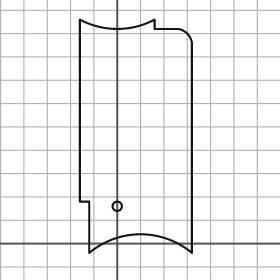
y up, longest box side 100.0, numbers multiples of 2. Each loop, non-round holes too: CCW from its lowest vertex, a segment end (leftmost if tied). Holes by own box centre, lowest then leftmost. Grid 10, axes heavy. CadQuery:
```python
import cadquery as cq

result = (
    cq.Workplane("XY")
    .moveTo(-12.0, -4.0)
    .threePointArc((10.0, 4.0), (32.0, -4.0))
    .lineTo(32.0, 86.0)
    .threePointArc((30.0, 90.0), (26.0, 92.0))
    .lineTo(16.0, 92.0)
    .lineTo(16.0, 96.0)
    .threePointArc((0.0, 92.0), (-16.0, 96.0))
    .lineTo(-16.0, 18.0)
    .lineTo(-12.0, 18.0)
    .close()
    .moveTo(0.0, 16.0)
    .circle(2.0)
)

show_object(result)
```